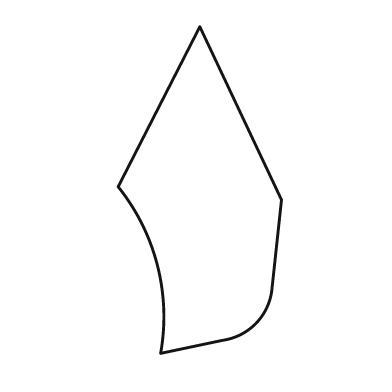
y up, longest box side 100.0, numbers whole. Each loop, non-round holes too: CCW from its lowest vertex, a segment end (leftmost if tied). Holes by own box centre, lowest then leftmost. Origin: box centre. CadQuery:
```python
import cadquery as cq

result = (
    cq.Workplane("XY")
    .moveTo(-12.0, -50.0)
    .lineTo(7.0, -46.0)
    .threePointArc((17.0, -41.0), (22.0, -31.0))
    .lineTo(25.0, -3.0)
    .lineTo(0.0, 50.0)
    .lineTo(-25.0, 1.0)
    .threePointArc((-13.0, -23.0), (-12.0, -50.0))
    .close()
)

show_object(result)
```